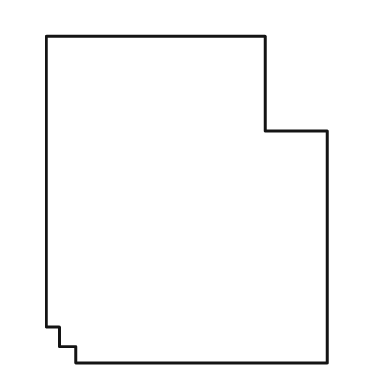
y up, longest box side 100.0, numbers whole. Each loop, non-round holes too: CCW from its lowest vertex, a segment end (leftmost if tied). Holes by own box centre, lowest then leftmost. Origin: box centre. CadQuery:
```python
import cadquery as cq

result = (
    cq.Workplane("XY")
    .moveTo(-34.0, -50.0)
    .lineTo(43.0, -50.0)
    .lineTo(43.0, 21.0)
    .lineTo(24.0, 21.0)
    .lineTo(24.0, 50.0)
    .lineTo(-43.0, 50.0)
    .lineTo(-43.0, -39.0)
    .lineTo(-39.0, -39.0)
    .lineTo(-39.0, -45.0)
    .lineTo(-34.0, -45.0)
    .close()
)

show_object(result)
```